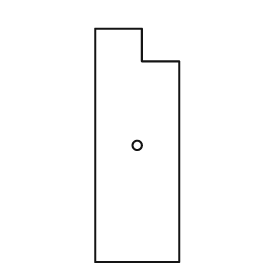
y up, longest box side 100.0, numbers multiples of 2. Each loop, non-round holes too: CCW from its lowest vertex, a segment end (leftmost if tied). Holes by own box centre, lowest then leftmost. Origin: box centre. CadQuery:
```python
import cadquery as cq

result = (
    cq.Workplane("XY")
    .moveTo(-18.0, -50.0)
    .lineTo(18.0, -50.0)
    .lineTo(18.0, 36.0)
    .lineTo(2.0, 36.0)
    .lineTo(2.0, 50.0)
    .lineTo(-18.0, 50.0)
    .close()
    .moveTo(0.0, 0.0)
    .circle(2.0)
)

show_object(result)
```